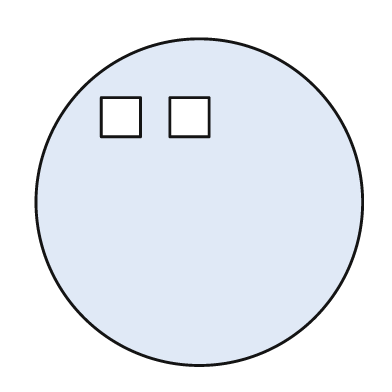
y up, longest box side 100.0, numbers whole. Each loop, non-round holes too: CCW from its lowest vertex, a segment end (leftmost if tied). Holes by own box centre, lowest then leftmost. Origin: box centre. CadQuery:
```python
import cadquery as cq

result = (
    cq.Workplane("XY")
    .moveTo(0.0, 0.0)
    .circle(50.0)
    .moveTo(-30.0, 20.0)
    .lineTo(-18.0, 20.0)
    .lineTo(-18.0, 32.0)
    .lineTo(-30.0, 32.0)
    .close()
    .moveTo(-9.0, 20.0)
    .lineTo(3.0, 20.0)
    .lineTo(3.0, 32.0)
    .lineTo(-9.0, 32.0)
    .close()
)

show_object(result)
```